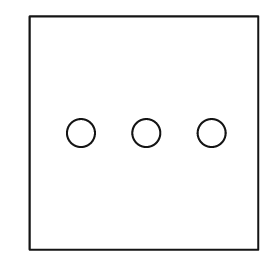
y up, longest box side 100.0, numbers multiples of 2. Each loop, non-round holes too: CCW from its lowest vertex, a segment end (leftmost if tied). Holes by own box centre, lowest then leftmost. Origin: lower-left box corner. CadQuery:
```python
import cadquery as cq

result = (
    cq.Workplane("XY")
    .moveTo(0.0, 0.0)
    .lineTo(98.0, 0.0)
    .lineTo(98.0, 100.0)
    .lineTo(0.0, 100.0)
    .close()
    .moveTo(22.0, 50.0)
    .circle(6.0)
    .moveTo(50.0, 50.0)
    .circle(6.0)
    .moveTo(78.0, 50.0)
    .circle(6.0)
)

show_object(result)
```